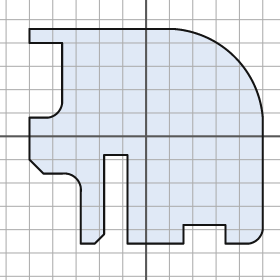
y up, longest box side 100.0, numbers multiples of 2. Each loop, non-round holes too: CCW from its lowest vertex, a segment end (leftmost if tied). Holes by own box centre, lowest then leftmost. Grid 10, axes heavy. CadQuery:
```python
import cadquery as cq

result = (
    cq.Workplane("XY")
    .moveTo(-28.0, -46.0)
    .lineTo(-22.0, -46.0)
    .lineTo(-18.0, -42.0)
    .lineTo(-18.0, -8.0)
    .lineTo(-8.0, -8.0)
    .lineTo(-8.0, -46.0)
    .lineTo(16.0, -46.0)
    .lineTo(16.0, -38.0)
    .lineTo(34.0, -38.0)
    .lineTo(34.0, -46.0)
    .lineTo(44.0, -46.0)
    .threePointArc((48.0, -44.0), (50.0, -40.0))
    .lineTo(50.0, 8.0)
    .threePointArc((38.0, 34.0), (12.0, 46.0))
    .lineTo(-50.0, 46.0)
    .lineTo(-50.0, 40.0)
    .lineTo(-36.0, 40.0)
    .lineTo(-36.0, 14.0)
    .threePointArc((-38.0, 10.0), (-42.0, 8.0))
    .lineTo(-50.0, 8.0)
    .lineTo(-50.0, -10.0)
    .lineTo(-44.0, -16.0)
    .lineTo(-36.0, -16.0)
    .threePointArc((-30.0, -18.0), (-28.0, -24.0))
    .close()
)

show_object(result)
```